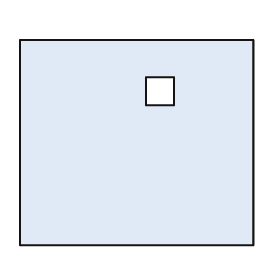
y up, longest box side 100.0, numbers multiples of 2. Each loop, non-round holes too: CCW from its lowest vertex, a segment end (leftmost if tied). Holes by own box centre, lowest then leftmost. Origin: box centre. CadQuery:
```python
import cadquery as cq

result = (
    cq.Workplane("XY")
    .moveTo(-50.0, -44.0)
    .lineTo(50.0, -44.0)
    .lineTo(50.0, 44.0)
    .lineTo(-50.0, 44.0)
    .close()
    .moveTo(4.0, 16.0)
    .lineTo(16.0, 16.0)
    .lineTo(16.0, 28.0)
    .lineTo(4.0, 28.0)
    .close()
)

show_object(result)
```